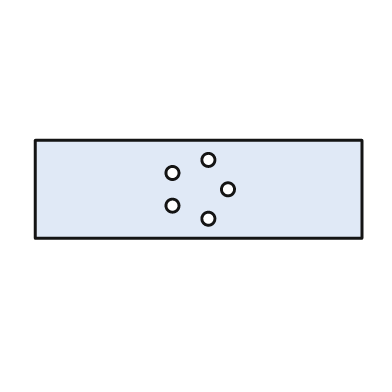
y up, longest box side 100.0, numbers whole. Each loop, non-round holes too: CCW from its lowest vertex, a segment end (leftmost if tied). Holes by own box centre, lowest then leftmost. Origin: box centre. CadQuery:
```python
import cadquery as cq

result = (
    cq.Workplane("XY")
    .moveTo(-50.0, -15.0)
    .lineTo(50.0, -15.0)
    .lineTo(50.0, 15.0)
    .lineTo(-50.0, 15.0)
    .close()
    .moveTo(3.0, -9.0)
    .circle(2.0)
    .moveTo(-8.0, -5.0)
    .circle(2.0)
    .moveTo(9.0, 0.0)
    .circle(2.0)
    .moveTo(-8.0, 5.0)
    .circle(2.0)
    .moveTo(3.0, 9.0)
    .circle(2.0)
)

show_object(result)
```